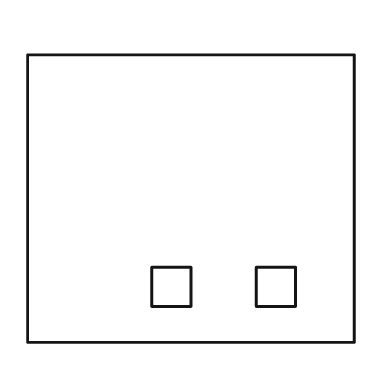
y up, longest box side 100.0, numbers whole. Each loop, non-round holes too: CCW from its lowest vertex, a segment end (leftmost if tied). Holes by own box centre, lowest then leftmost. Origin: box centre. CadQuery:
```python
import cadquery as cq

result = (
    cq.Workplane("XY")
    .moveTo(-50.0, -44.0)
    .lineTo(50.0, -44.0)
    .lineTo(50.0, 44.0)
    .lineTo(-50.0, 44.0)
    .close()
    .moveTo(-12.0, -33.0)
    .lineTo(0.0, -33.0)
    .lineTo(0.0, -21.0)
    .lineTo(-12.0, -21.0)
    .close()
    .moveTo(20.0, -33.0)
    .lineTo(32.0, -33.0)
    .lineTo(32.0, -21.0)
    .lineTo(20.0, -21.0)
    .close()
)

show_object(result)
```